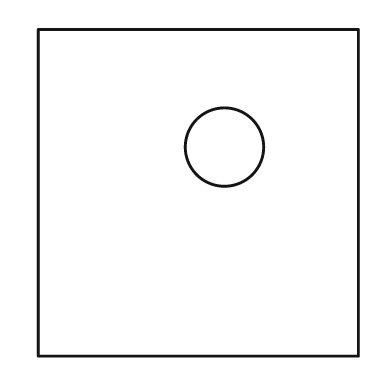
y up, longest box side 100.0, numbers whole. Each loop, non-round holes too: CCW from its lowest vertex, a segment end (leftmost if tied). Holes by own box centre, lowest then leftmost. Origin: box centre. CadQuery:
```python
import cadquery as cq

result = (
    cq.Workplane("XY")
    .moveTo(-49.0, -50.0)
    .lineTo(49.0, -50.0)
    .lineTo(49.0, 50.0)
    .lineTo(-49.0, 50.0)
    .close()
    .moveTo(8.0, 14.0)
    .circle(12.0)
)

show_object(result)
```